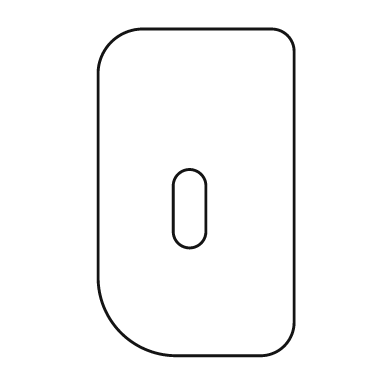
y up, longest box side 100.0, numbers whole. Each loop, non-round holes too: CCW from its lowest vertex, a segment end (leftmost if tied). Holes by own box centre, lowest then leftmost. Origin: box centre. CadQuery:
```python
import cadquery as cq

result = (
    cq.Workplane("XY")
    .moveTo(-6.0, -50.0)
    .lineTo(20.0, -50.0)
    .threePointArc((27.0, -47.0), (30.0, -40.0))
    .lineTo(30.0, 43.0)
    .threePointArc((28.0, 48.0), (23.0, 50.0))
    .lineTo(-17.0, 50.0)
    .threePointArc((-26.0, 46.0), (-30.0, 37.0))
    .lineTo(-30.0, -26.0)
    .threePointArc((-23.0, -43.0), (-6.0, -50.0))
    .close()
    .moveTo(-7.0, -12.0)
    .threePointArc((-2.0, -17.0), (3.0, -12.0))
    .lineTo(3.0, 2.0)
    .threePointArc((-2.0, 7.0), (-7.0, 2.0))
    .close()
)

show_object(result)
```